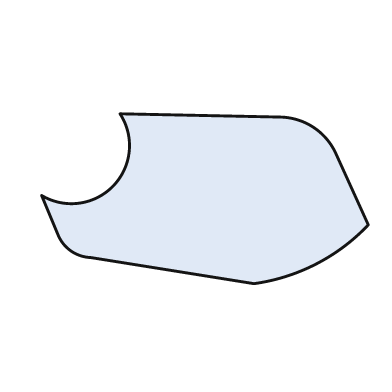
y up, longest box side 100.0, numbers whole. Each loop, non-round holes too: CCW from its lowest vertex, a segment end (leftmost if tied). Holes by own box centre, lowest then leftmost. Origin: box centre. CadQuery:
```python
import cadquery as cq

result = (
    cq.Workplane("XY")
    .moveTo(15.0, -26.0)
    .threePointArc((34.0, -20.0), (50.0, -8.0))
    .lineTo(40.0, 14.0)
    .threePointArc((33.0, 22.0), (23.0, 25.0))
    .lineTo(-26.0, 26.0)
    .threePointArc((-28.0, 4.0), (-50.0, 1.0))
    .lineTo(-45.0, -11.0)
    .threePointArc((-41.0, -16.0), (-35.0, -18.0))
    .close()
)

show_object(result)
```